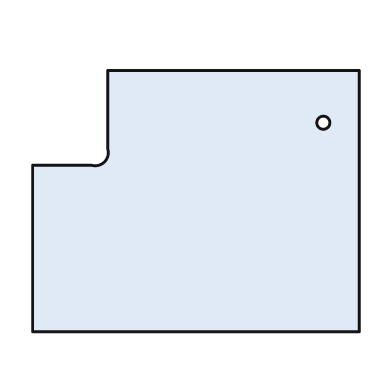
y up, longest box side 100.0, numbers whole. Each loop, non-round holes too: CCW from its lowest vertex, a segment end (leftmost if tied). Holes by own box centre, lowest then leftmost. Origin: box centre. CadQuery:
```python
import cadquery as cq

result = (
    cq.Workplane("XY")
    .moveTo(-50.0, -40.0)
    .lineTo(50.0, -40.0)
    .lineTo(50.0, 40.0)
    .lineTo(-27.0, 40.0)
    .lineTo(-27.0, 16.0)
    .threePointArc((-28.0, 12.0), (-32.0, 11.0))
    .lineTo(-50.0, 11.0)
    .close()
    .moveTo(39.0, 24.0)
    .circle(2.0)
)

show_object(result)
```